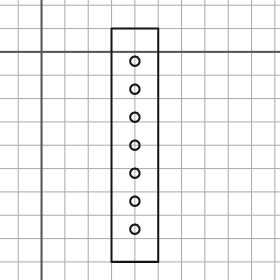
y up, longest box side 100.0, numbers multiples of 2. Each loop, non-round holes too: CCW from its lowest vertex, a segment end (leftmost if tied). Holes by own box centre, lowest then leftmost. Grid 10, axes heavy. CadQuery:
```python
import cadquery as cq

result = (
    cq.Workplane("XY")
    .moveTo(30.0, -90.0)
    .lineTo(50.0, -90.0)
    .lineTo(50.0, 10.0)
    .lineTo(30.0, 10.0)
    .close()
    .moveTo(40.0, -76.0)
    .circle(2.0)
    .moveTo(40.0, -64.0)
    .circle(2.0)
    .moveTo(40.0, -52.0)
    .circle(2.0)
    .moveTo(40.0, -40.0)
    .circle(2.0)
    .moveTo(40.0, -28.0)
    .circle(2.0)
    .moveTo(40.0, -16.0)
    .circle(2.0)
    .moveTo(40.0, -4.0)
    .circle(2.0)
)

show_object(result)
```